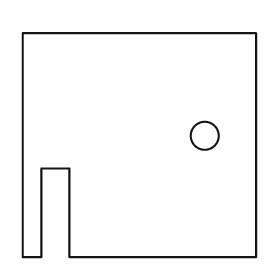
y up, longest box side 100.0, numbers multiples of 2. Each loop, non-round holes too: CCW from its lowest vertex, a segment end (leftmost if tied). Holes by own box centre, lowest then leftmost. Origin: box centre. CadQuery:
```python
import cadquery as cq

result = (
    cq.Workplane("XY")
    .moveTo(-50.0, -48.0)
    .lineTo(-42.0, -48.0)
    .lineTo(-42.0, -10.0)
    .lineTo(-30.0, -10.0)
    .lineTo(-30.0, -48.0)
    .lineTo(50.0, -48.0)
    .lineTo(50.0, 48.0)
    .lineTo(-50.0, 48.0)
    .close()
    .moveTo(28.0, 4.0)
    .circle(6.0)
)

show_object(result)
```